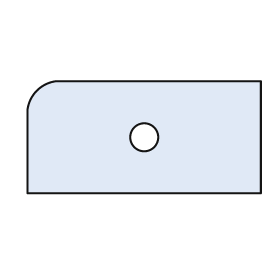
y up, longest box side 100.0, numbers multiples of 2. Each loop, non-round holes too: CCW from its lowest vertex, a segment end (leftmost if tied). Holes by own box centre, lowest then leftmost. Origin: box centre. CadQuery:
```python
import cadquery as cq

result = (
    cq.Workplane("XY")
    .moveTo(-50.0, -24.0)
    .lineTo(50.0, -24.0)
    .lineTo(50.0, 24.0)
    .lineTo(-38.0, 24.0)
    .threePointArc((-46.0, 20.0), (-50.0, 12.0))
    .close()
    .moveTo(0.0, 0.0)
    .circle(6.0)
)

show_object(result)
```